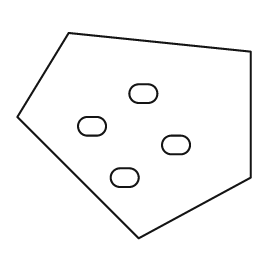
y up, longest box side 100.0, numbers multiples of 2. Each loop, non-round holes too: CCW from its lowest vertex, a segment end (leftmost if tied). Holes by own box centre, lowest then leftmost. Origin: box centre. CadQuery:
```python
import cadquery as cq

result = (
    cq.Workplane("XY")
    .moveTo(2.0, -44.0)
    .lineTo(50.0, -18.0)
    .lineTo(50.0, 36.0)
    .lineTo(-28.0, 44.0)
    .lineTo(-50.0, 8.0)
    .close()
    .moveTo(-6.0, -22.0)
    .lineTo(-2.0, -22.0)
    .threePointArc((2.0, -18.0), (-2.0, -14.0))
    .lineTo(-6.0, -14.0)
    .threePointArc((-10.0, -18.0), (-6.0, -22.0))
    .close()
    .moveTo(16.0, -8.0)
    .lineTo(20.0, -8.0)
    .threePointArc((24.0, -4.0), (20.0, 0.0))
    .lineTo(16.0, 0.0)
    .threePointArc((12.0, -4.0), (16.0, -8.0))
    .close()
    .moveTo(-20.0, 0.0)
    .lineTo(-16.0, 0.0)
    .threePointArc((-12.0, 4.0), (-16.0, 8.0))
    .lineTo(-20.0, 8.0)
    .threePointArc((-24.0, 4.0), (-20.0, 0.0))
    .close()
    .moveTo(2.0, 14.0)
    .lineTo(6.0, 14.0)
    .threePointArc((10.0, 18.0), (6.0, 22.0))
    .lineTo(2.0, 22.0)
    .threePointArc((-2.0, 18.0), (2.0, 14.0))
    .close()
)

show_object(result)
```